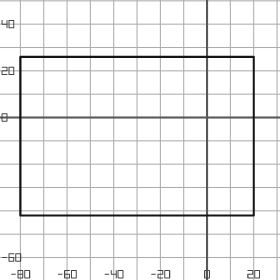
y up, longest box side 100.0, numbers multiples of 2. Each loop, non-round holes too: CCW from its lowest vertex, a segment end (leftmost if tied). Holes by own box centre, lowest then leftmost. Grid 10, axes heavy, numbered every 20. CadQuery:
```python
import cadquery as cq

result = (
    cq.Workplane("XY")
    .moveTo(-80.0, -42.0)
    .lineTo(20.0, -42.0)
    .lineTo(20.0, 26.0)
    .lineTo(-80.0, 26.0)
    .close()
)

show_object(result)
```